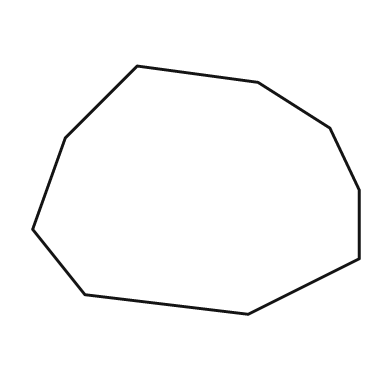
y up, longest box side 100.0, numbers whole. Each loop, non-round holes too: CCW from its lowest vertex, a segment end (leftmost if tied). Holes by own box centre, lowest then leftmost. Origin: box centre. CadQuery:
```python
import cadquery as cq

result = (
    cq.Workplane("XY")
    .moveTo(16.0, -38.0)
    .lineTo(50.0, -21.0)
    .lineTo(50.0, 0.0)
    .lineTo(41.0, 19.0)
    .lineTo(19.0, 33.0)
    .lineTo(-18.0, 38.0)
    .lineTo(-40.0, 16.0)
    .lineTo(-50.0, -12.0)
    .lineTo(-34.0, -32.0)
    .close()
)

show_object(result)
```